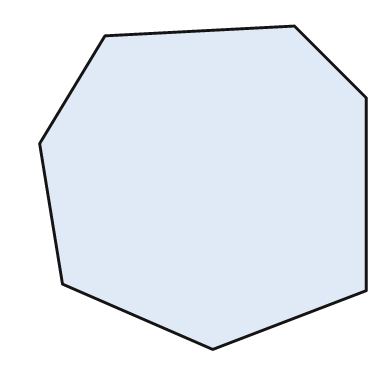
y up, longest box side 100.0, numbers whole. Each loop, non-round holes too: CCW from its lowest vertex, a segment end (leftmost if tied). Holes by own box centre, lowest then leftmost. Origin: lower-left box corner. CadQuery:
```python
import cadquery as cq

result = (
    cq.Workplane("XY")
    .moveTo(53.0, 0.0)
    .lineTo(100.0, 18.0)
    .lineTo(100.0, 77.0)
    .lineTo(78.0, 99.0)
    .lineTo(20.0, 96.0)
    .lineTo(0.0, 63.0)
    .lineTo(7.0, 20.0)
    .close()
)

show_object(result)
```